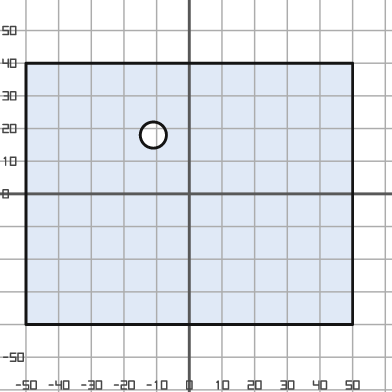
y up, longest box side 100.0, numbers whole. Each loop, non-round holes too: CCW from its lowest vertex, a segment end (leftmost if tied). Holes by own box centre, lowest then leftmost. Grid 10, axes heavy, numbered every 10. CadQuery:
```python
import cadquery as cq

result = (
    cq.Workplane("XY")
    .moveTo(-50.0, -40.0)
    .lineTo(50.0, -40.0)
    .lineTo(50.0, 40.0)
    .lineTo(-50.0, 40.0)
    .close()
    .moveTo(-11.0, 18.0)
    .circle(4.0)
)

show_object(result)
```